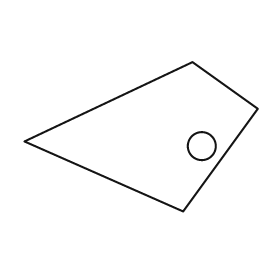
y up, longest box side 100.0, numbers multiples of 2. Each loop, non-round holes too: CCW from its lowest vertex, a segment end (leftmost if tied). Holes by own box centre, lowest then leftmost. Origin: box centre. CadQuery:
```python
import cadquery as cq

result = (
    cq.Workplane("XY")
    .moveTo(18.0, -32.0)
    .lineTo(50.0, 12.0)
    .lineTo(22.0, 32.0)
    .lineTo(-50.0, -2.0)
    .close()
    .moveTo(26.0, -4.0)
    .circle(6.0)
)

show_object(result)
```